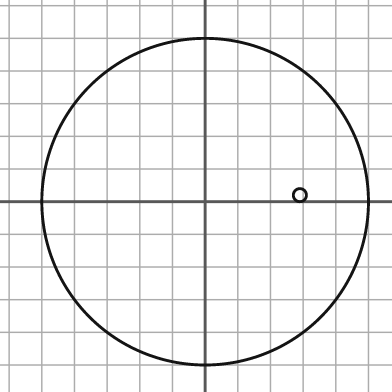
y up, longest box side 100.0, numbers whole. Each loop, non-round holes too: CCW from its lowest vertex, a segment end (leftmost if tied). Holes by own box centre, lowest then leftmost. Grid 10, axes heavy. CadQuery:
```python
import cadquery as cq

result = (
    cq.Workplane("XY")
    .moveTo(0.0, 0.0)
    .circle(50.0)
    .moveTo(29.0, 2.0)
    .circle(2.0)
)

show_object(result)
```